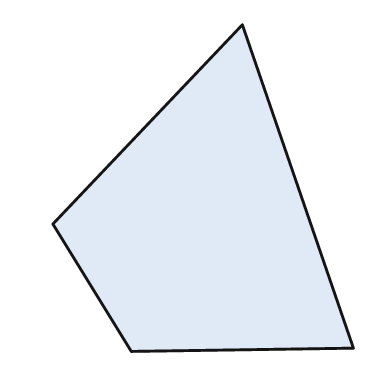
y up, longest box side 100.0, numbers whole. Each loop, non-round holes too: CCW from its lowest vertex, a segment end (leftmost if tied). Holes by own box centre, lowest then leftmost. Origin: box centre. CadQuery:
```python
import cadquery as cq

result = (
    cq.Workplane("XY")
    .moveTo(-22.0, -50.0)
    .lineTo(46.0, -49.0)
    .lineTo(12.0, 50.0)
    .lineTo(-46.0, -11.0)
    .close()
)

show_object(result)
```